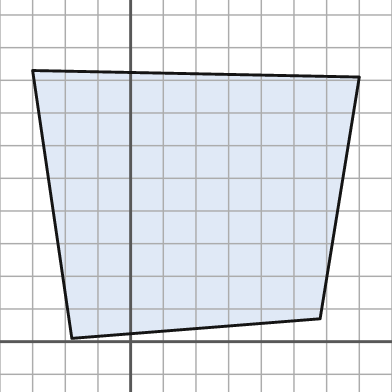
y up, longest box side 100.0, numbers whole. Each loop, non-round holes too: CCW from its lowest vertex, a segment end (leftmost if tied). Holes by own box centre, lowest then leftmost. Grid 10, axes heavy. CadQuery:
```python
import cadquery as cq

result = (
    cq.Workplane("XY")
    .moveTo(-18.0, 1.0)
    .lineTo(58.0, 7.0)
    .lineTo(70.0, 81.0)
    .lineTo(-30.0, 83.0)
    .close()
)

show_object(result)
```